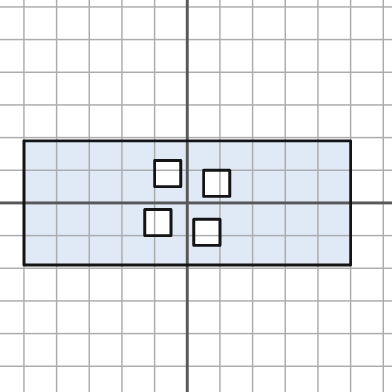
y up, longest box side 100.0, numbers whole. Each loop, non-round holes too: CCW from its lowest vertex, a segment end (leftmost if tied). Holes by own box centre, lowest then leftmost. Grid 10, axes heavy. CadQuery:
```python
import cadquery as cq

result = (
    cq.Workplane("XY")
    .moveTo(-50.0, -19.0)
    .lineTo(50.0, -19.0)
    .lineTo(50.0, 19.0)
    .lineTo(-50.0, 19.0)
    .close()
    .moveTo(2.0, -13.0)
    .lineTo(10.0, -13.0)
    .lineTo(10.0, -5.0)
    .lineTo(2.0, -5.0)
    .close()
    .moveTo(-13.0, -10.0)
    .lineTo(-5.0, -10.0)
    .lineTo(-5.0, -2.0)
    .lineTo(-13.0, -2.0)
    .close()
    .moveTo(5.0, 2.0)
    .lineTo(13.0, 2.0)
    .lineTo(13.0, 10.0)
    .lineTo(5.0, 10.0)
    .close()
    .moveTo(-10.0, 5.0)
    .lineTo(-2.0, 5.0)
    .lineTo(-2.0, 13.0)
    .lineTo(-10.0, 13.0)
    .close()
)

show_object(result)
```